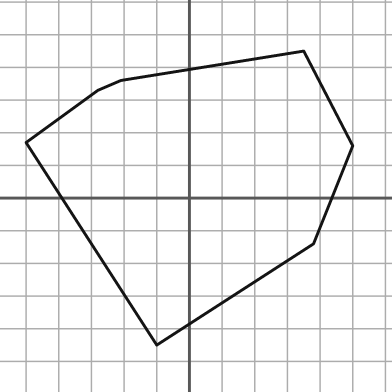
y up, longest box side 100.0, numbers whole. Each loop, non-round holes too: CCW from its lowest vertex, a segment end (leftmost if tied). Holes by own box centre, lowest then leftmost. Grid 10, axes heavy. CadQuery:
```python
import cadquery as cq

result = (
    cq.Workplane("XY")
    .moveTo(-10.0, -45.0)
    .lineTo(38.0, -14.0)
    .lineTo(50.0, 16.0)
    .lineTo(35.0, 45.0)
    .lineTo(-21.0, 36.0)
    .lineTo(-28.0, 33.0)
    .lineTo(-50.0, 17.0)
    .close()
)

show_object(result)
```